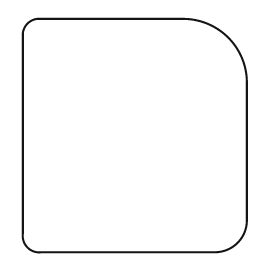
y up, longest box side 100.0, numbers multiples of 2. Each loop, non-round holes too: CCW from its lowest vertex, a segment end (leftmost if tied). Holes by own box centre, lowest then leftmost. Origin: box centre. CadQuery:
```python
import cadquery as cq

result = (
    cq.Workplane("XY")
    .moveTo(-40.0, -50.0)
    .lineTo(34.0, -50.0)
    .threePointArc((44.0, -46.0), (48.0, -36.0))
    .lineTo(48.0, 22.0)
    .threePointArc((40.0, 42.0), (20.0, 50.0))
    .lineTo(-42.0, 50.0)
    .threePointArc((-46.0, 48.0), (-48.0, 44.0))
    .lineTo(-48.0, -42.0)
    .threePointArc((-46.0, -48.0), (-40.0, -50.0))
    .close()
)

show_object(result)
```